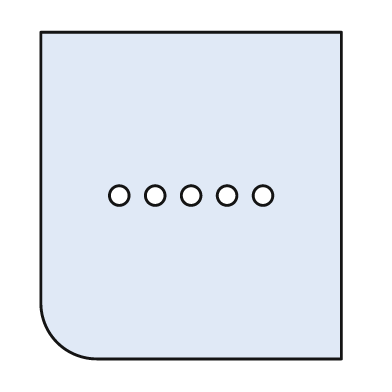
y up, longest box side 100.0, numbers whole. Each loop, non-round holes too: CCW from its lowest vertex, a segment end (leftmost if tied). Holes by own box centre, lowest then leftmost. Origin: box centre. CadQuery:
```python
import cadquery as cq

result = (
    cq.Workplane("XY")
    .moveTo(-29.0, -50.0)
    .lineTo(46.0, -50.0)
    .lineTo(46.0, 50.0)
    .lineTo(-46.0, 50.0)
    .lineTo(-46.0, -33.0)
    .threePointArc((-41.0, -45.0), (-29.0, -50.0))
    .close()
    .moveTo(-22.0, 0.0)
    .circle(3.0)
    .moveTo(-11.0, 0.0)
    .circle(3.0)
    .moveTo(0.0, 0.0)
    .circle(3.0)
    .moveTo(11.0, 0.0)
    .circle(3.0)
    .moveTo(22.0, 0.0)
    .circle(3.0)
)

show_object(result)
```